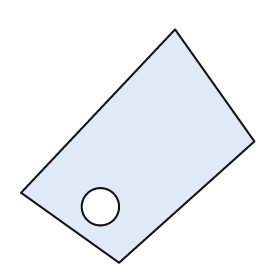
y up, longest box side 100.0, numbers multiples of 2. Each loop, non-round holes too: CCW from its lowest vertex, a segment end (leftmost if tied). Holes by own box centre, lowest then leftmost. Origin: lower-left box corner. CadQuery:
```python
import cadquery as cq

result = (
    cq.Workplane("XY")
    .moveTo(42.0, 0.0)
    .lineTo(100.0, 52.0)
    .lineTo(66.0, 100.0)
    .lineTo(0.0, 30.0)
    .close()
    .moveTo(34.0, 24.0)
    .circle(8.0)
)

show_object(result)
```